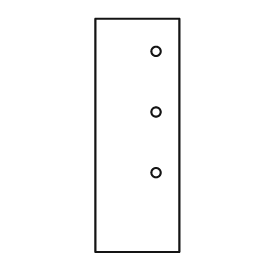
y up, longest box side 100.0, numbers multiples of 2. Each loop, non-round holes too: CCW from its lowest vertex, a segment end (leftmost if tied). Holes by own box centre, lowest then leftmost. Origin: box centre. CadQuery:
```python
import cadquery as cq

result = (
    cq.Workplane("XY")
    .moveTo(-18.0, -50.0)
    .lineTo(18.0, -50.0)
    .lineTo(18.0, 50.0)
    .lineTo(-18.0, 50.0)
    .close()
    .moveTo(8.0, -16.0)
    .circle(2.0)
    .moveTo(8.0, 10.0)
    .circle(2.0)
    .moveTo(8.0, 36.0)
    .circle(2.0)
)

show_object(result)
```